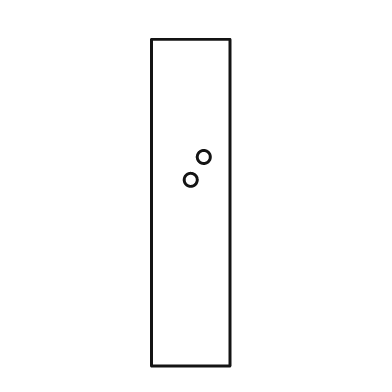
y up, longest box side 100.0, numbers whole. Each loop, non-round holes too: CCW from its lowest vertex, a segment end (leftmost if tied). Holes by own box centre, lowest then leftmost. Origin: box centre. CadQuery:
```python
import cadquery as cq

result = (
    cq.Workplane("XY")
    .moveTo(-12.0, -50.0)
    .lineTo(12.0, -50.0)
    .lineTo(12.0, 50.0)
    .lineTo(-12.0, 50.0)
    .close()
    .moveTo(0.0, 7.0)
    .circle(2.0)
    .moveTo(4.0, 14.0)
    .circle(2.0)
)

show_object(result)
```